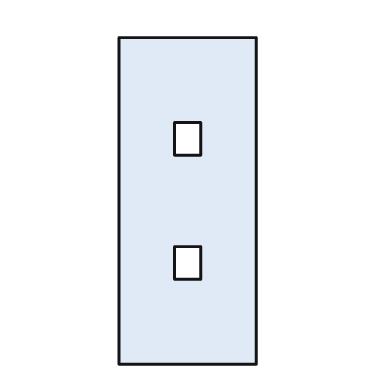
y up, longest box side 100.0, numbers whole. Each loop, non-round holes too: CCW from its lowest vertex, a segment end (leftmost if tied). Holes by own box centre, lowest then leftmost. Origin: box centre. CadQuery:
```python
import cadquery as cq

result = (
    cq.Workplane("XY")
    .moveTo(-21.0, -50.0)
    .lineTo(21.0, -50.0)
    .lineTo(21.0, 50.0)
    .lineTo(-21.0, 50.0)
    .close()
    .moveTo(-4.0, -24.0)
    .lineTo(4.0, -24.0)
    .lineTo(4.0, -14.0)
    .lineTo(-4.0, -14.0)
    .close()
    .moveTo(-4.0, 14.0)
    .lineTo(4.0, 14.0)
    .lineTo(4.0, 24.0)
    .lineTo(-4.0, 24.0)
    .close()
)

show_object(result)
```